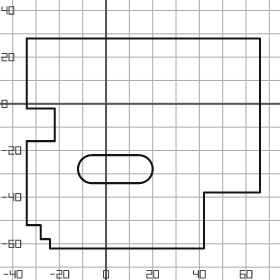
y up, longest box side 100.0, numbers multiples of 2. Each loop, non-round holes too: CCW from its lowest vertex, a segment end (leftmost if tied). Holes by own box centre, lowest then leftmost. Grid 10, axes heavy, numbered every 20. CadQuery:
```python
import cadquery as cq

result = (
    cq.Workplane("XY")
    .moveTo(-24.0, -62.0)
    .lineTo(42.0, -62.0)
    .lineTo(42.0, -38.0)
    .lineTo(66.0, -38.0)
    .lineTo(66.0, 28.0)
    .lineTo(-34.0, 28.0)
    .lineTo(-34.0, -2.0)
    .lineTo(-22.0, -2.0)
    .lineTo(-22.0, -16.0)
    .lineTo(-34.0, -16.0)
    .lineTo(-34.0, -52.0)
    .lineTo(-28.0, -52.0)
    .lineTo(-28.0, -58.0)
    .lineTo(-24.0, -58.0)
    .close()
    .moveTo(-6.0, -34.0)
    .lineTo(14.0, -34.0)
    .threePointArc((20.0, -28.0), (14.0, -22.0))
    .lineTo(-6.0, -22.0)
    .threePointArc((-12.0, -28.0), (-6.0, -34.0))
    .close()
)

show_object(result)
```